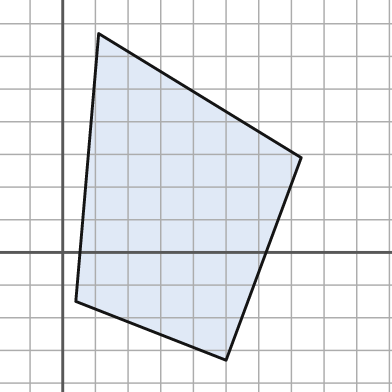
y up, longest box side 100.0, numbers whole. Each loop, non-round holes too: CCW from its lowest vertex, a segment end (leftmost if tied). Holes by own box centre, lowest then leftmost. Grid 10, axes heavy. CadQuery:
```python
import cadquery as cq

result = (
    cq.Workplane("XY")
    .moveTo(50.0, -33.0)
    .lineTo(73.0, 29.0)
    .lineTo(11.0, 67.0)
    .lineTo(4.0, -15.0)
    .close()
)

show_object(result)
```